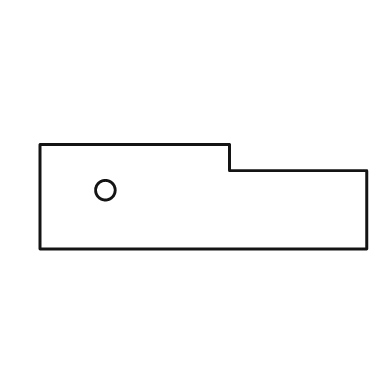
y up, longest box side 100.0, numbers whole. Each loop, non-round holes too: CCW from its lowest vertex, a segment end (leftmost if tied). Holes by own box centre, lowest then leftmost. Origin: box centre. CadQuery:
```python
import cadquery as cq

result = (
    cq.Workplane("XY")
    .moveTo(-50.0, -16.0)
    .lineTo(50.0, -16.0)
    .lineTo(50.0, 8.0)
    .lineTo(8.0, 8.0)
    .lineTo(8.0, 16.0)
    .lineTo(-50.0, 16.0)
    .close()
    .moveTo(-30.0, 2.0)
    .circle(3.0)
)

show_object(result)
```